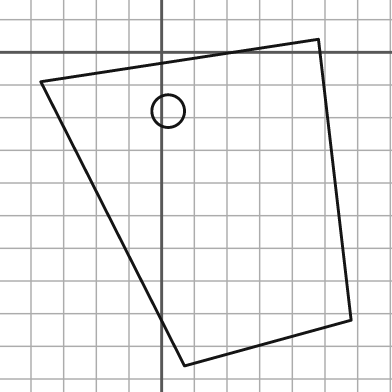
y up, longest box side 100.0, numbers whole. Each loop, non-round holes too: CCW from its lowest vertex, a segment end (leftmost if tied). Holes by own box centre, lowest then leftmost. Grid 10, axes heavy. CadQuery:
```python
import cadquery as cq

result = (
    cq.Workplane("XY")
    .moveTo(7.0, -96.0)
    .lineTo(58.0, -82.0)
    .lineTo(48.0, 4.0)
    .lineTo(-37.0, -9.0)
    .close()
    .moveTo(2.0, -18.0)
    .circle(5.0)
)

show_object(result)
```